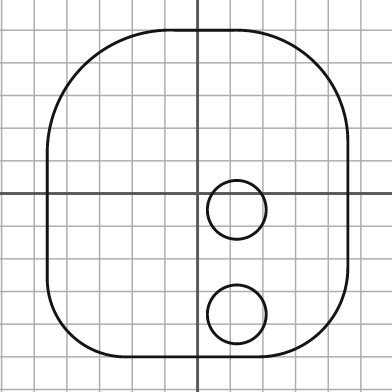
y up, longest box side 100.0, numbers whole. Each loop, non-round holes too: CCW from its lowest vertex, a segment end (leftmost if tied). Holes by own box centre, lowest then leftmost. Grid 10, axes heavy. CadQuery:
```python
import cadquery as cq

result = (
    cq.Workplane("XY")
    .moveTo(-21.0, -50.0)
    .lineTo(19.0, -50.0)
    .threePointArc((38.0, -42.0), (46.0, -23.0))
    .lineTo(46.0, 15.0)
    .threePointArc((36.0, 40.0), (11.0, 50.0))
    .lineTo(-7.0, 50.0)
    .threePointArc((-35.0, 39.0), (-46.0, 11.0))
    .lineTo(-46.0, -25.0)
    .threePointArc((-39.0, -43.0), (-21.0, -50.0))
    .close()
    .moveTo(12.0, -37.0)
    .circle(9.0)
    .moveTo(12.0, -5.0)
    .circle(9.0)
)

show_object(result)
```